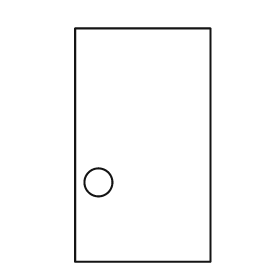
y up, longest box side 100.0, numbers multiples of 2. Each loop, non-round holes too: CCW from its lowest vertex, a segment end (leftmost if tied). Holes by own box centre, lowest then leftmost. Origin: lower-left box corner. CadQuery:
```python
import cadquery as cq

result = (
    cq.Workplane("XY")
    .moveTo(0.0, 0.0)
    .lineTo(58.0, 0.0)
    .lineTo(58.0, 100.0)
    .lineTo(0.0, 100.0)
    .close()
    .moveTo(10.0, 34.0)
    .circle(6.0)
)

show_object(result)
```